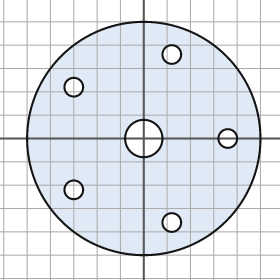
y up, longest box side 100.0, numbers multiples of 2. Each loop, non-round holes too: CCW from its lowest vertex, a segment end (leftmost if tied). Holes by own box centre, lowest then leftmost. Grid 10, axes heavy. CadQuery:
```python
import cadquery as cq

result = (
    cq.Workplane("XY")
    .moveTo(0.0, 0.0)
    .circle(50.0)
    .moveTo(12.0, -36.0)
    .circle(4.0)
    .moveTo(-30.0, -22.0)
    .circle(4.0)
    .moveTo(0.0, 0.0)
    .circle(8.0)
    .moveTo(36.0, 0.0)
    .circle(4.0)
    .moveTo(-30.0, 22.0)
    .circle(4.0)
    .moveTo(12.0, 36.0)
    .circle(4.0)
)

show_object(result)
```